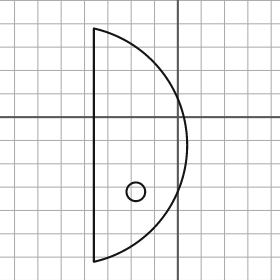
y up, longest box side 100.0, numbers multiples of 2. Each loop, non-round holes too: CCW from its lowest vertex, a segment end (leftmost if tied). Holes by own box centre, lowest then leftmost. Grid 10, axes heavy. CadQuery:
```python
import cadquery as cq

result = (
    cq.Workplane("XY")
    .moveTo(-36.0, -62.0)
    .threePointArc((4.0, -12.0), (-36.0, 38.0))
    .close()
    .moveTo(-18.0, -32.0)
    .circle(4.0)
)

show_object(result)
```